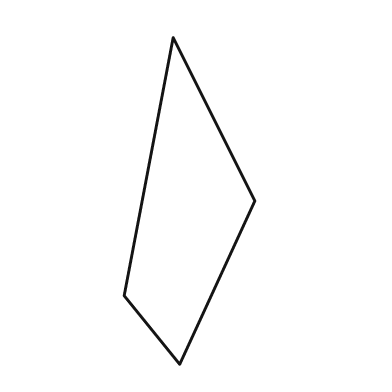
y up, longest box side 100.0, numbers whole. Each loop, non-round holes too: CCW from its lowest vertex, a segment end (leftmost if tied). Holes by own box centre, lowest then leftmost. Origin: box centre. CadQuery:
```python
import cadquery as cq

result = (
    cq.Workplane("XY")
    .moveTo(-3.0, -50.0)
    .lineTo(20.0, 0.0)
    .lineTo(-5.0, 50.0)
    .lineTo(-20.0, -29.0)
    .close()
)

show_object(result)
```